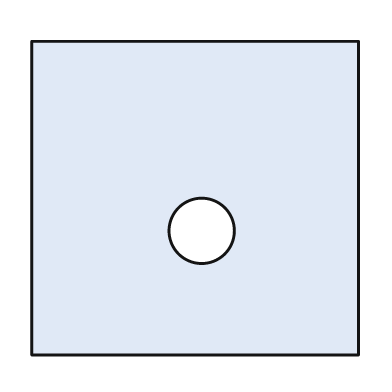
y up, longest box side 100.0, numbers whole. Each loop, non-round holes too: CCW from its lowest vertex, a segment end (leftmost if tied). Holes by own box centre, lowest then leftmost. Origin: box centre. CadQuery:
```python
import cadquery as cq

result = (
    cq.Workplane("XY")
    .moveTo(-50.0, -48.0)
    .lineTo(50.0, -48.0)
    .lineTo(50.0, 48.0)
    .lineTo(-50.0, 48.0)
    .close()
    .moveTo(2.0, -10.0)
    .circle(10.0)
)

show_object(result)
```